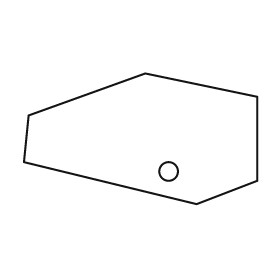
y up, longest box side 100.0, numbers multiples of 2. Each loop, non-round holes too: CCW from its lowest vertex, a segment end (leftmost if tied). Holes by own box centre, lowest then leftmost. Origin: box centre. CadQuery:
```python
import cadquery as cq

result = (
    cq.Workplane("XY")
    .moveTo(24.0, -28.0)
    .lineTo(50.0, -18.0)
    .lineTo(50.0, 18.0)
    .lineTo(2.0, 28.0)
    .lineTo(-48.0, 10.0)
    .lineTo(-50.0, -10.0)
    .close()
    .moveTo(12.0, -14.0)
    .circle(4.0)
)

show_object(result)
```